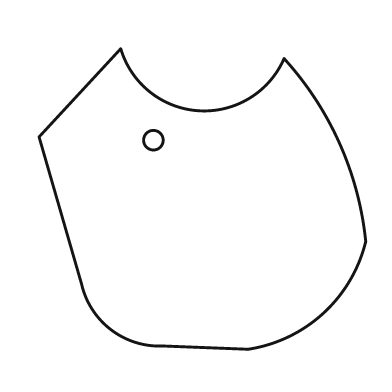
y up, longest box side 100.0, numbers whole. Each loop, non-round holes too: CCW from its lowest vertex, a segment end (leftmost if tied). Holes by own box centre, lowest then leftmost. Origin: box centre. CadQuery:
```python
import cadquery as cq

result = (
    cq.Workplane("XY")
    .moveTo(14.0, -46.0)
    .threePointArc((37.0, -35.0), (50.0, -13.0))
    .threePointArc((42.0, 17.0), (25.0, 43.0))
    .threePointArc((-1.0, 27.0), (-25.0, 46.0))
    .lineTo(-50.0, 19.0)
    .lineTo(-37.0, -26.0)
    .threePointArc((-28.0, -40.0), (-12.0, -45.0))
    .close()
    .moveTo(-15.0, 18.0)
    .circle(3.0)
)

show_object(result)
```